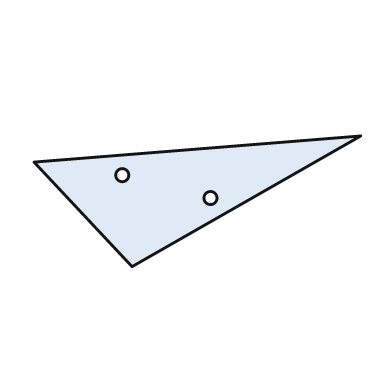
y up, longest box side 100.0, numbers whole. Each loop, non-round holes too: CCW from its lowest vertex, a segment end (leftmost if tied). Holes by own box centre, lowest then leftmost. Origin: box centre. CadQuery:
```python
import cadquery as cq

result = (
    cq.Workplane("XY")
    .moveTo(-20.0, -20.0)
    .lineTo(50.0, 20.0)
    .lineTo(-50.0, 12.0)
    .close()
    .moveTo(4.0, 1.0)
    .circle(2.0)
    .moveTo(-23.0, 8.0)
    .circle(2.0)
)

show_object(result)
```